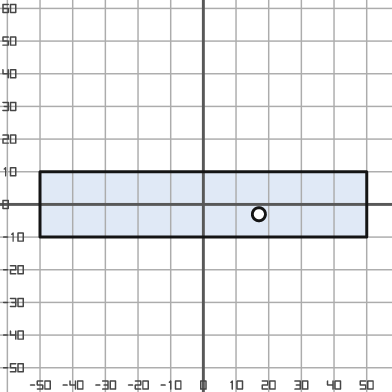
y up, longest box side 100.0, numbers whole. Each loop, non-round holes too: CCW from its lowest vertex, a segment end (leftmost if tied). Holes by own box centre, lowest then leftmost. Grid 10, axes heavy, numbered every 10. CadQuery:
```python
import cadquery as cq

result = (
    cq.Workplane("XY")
    .moveTo(-50.0, -10.0)
    .lineTo(50.0, -10.0)
    .lineTo(50.0, 10.0)
    .lineTo(-50.0, 10.0)
    .close()
    .moveTo(17.0, -3.0)
    .circle(2.0)
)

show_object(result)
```